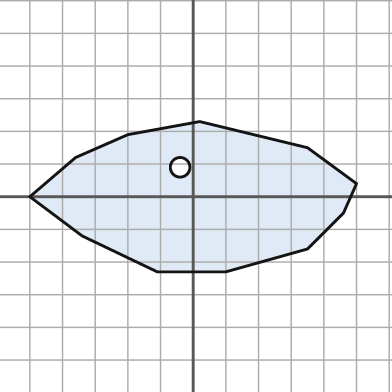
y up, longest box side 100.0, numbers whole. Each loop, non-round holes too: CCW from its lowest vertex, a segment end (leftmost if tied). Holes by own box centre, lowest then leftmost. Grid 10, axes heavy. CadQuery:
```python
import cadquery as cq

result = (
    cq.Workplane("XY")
    .moveTo(-11.0, -23.0)
    .lineTo(10.0, -23.0)
    .lineTo(35.0, -16.0)
    .lineTo(46.0, -5.0)
    .lineTo(50.0, 4.0)
    .lineTo(35.0, 15.0)
    .lineTo(2.0, 23.0)
    .lineTo(-20.0, 19.0)
    .lineTo(-36.0, 12.0)
    .lineTo(-50.0, 0.0)
    .lineTo(-34.0, -12.0)
    .close()
    .moveTo(-4.0, 9.0)
    .circle(3.0)
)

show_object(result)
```